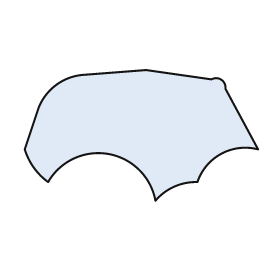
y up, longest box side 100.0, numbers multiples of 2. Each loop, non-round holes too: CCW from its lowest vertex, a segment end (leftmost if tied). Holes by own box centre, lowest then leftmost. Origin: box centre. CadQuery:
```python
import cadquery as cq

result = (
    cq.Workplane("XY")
    .moveTo(6.0, -28.0)
    .threePointArc((14.0, -22.0), (24.0, -20.0))
    .threePointArc((34.0, -8.0), (50.0, -6.0))
    .lineTo(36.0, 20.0)
    .threePointArc((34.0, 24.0), (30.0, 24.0))
    .lineTo(2.0, 28.0)
    .lineTo(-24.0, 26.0)
    .threePointArc((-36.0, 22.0), (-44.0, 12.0))
    .lineTo(-50.0, -6.0)
    .threePointArc((-46.0, -14.0), (-40.0, -20.0))
    .threePointArc((-14.0, -8.0), (6.0, -28.0))
    .close()
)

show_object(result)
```